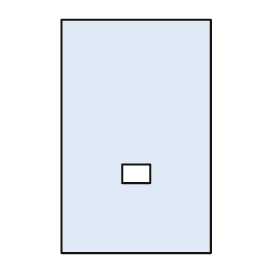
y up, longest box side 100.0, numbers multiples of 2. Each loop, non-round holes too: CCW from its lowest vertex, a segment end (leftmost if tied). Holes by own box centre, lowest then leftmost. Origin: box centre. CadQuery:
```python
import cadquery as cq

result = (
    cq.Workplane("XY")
    .moveTo(-32.0, -50.0)
    .lineTo(32.0, -50.0)
    .lineTo(32.0, 50.0)
    .lineTo(-32.0, 50.0)
    .close()
    .moveTo(-6.0, -20.0)
    .lineTo(6.0, -20.0)
    .lineTo(6.0, -12.0)
    .lineTo(-6.0, -12.0)
    .close()
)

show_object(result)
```